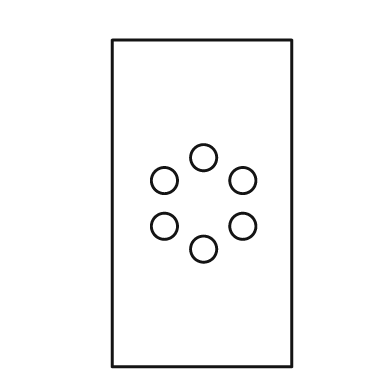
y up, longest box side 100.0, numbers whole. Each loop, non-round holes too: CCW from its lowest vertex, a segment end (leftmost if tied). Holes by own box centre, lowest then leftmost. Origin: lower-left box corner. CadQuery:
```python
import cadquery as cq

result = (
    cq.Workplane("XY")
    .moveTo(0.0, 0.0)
    .lineTo(55.0, 0.0)
    .lineTo(55.0, 100.0)
    .lineTo(0.0, 100.0)
    .close()
    .moveTo(28.0, 36.0)
    .circle(4.0)
    .moveTo(16.0, 43.0)
    .circle(4.0)
    .moveTo(40.0, 43.0)
    .circle(4.0)
    .moveTo(16.0, 57.0)
    .circle(4.0)
    .moveTo(40.0, 57.0)
    .circle(4.0)
    .moveTo(28.0, 64.0)
    .circle(4.0)
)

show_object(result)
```